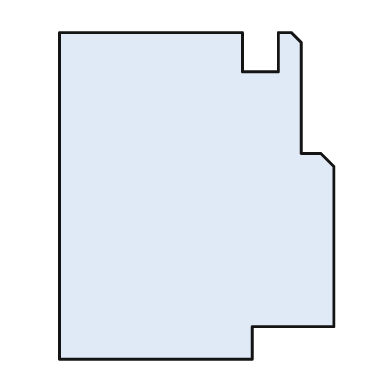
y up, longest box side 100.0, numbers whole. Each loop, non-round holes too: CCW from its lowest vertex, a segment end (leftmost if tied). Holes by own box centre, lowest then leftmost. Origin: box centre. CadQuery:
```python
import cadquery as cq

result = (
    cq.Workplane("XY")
    .moveTo(-42.0, -50.0)
    .lineTo(17.0, -50.0)
    .lineTo(17.0, -40.0)
    .lineTo(42.0, -40.0)
    .lineTo(42.0, 9.0)
    .lineTo(38.0, 13.0)
    .lineTo(32.0, 13.0)
    .lineTo(32.0, 47.0)
    .lineTo(29.0, 50.0)
    .lineTo(25.0, 50.0)
    .lineTo(25.0, 38.0)
    .lineTo(14.0, 38.0)
    .lineTo(14.0, 50.0)
    .lineTo(-42.0, 50.0)
    .close()
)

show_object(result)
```